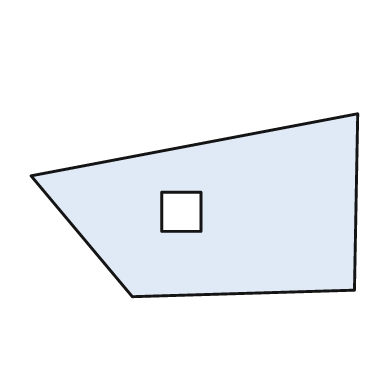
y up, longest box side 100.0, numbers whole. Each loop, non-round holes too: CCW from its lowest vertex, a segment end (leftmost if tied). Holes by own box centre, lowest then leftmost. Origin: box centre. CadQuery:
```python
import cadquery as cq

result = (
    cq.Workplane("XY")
    .moveTo(-19.0, -28.0)
    .lineTo(49.0, -26.0)
    .lineTo(50.0, 28.0)
    .lineTo(-50.0, 9.0)
    .close()
    .moveTo(-10.0, -8.0)
    .lineTo(2.0, -8.0)
    .lineTo(2.0, 4.0)
    .lineTo(-10.0, 4.0)
    .close()
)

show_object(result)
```